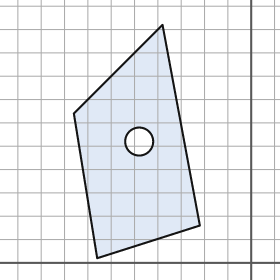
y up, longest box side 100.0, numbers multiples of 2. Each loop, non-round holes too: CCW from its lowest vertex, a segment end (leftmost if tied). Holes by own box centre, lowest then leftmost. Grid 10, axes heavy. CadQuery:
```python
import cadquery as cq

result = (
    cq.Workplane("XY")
    .moveTo(-66.0, 2.0)
    .lineTo(-22.0, 16.0)
    .lineTo(-38.0, 102.0)
    .lineTo(-76.0, 64.0)
    .close()
    .moveTo(-48.0, 52.0)
    .circle(6.0)
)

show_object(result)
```